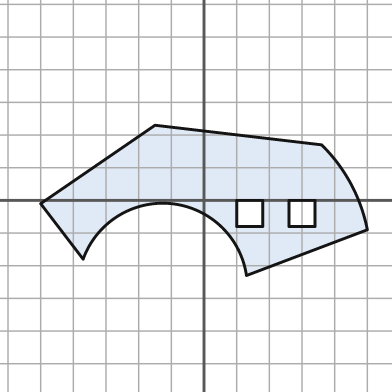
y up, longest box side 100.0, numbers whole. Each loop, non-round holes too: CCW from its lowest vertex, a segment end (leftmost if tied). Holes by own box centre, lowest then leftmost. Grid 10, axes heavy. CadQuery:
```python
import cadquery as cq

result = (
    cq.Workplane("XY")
    .moveTo(13.0, -23.0)
    .lineTo(50.0, -9.0)
    .threePointArc((45.0, 5.0), (36.0, 17.0))
    .lineTo(-15.0, 23.0)
    .lineTo(-50.0, -1.0)
    .lineTo(-37.0, -18.0)
    .threePointArc((-10.0, -1.0), (13.0, -23.0))
    .close()
    .moveTo(10.0, -8.0)
    .lineTo(18.0, -8.0)
    .lineTo(18.0, 0.0)
    .lineTo(10.0, 0.0)
    .close()
    .moveTo(26.0, -8.0)
    .lineTo(34.0, -8.0)
    .lineTo(34.0, 0.0)
    .lineTo(26.0, 0.0)
    .close()
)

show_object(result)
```